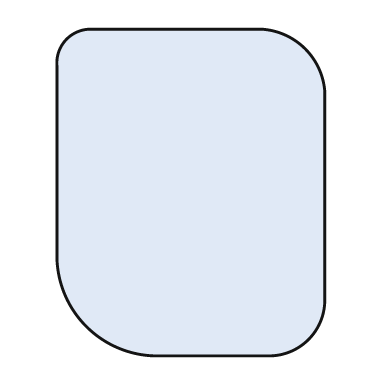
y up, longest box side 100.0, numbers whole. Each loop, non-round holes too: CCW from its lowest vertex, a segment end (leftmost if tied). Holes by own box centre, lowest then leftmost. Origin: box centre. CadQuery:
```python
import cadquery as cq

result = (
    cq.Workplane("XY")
    .moveTo(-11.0, -50.0)
    .lineTo(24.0, -50.0)
    .threePointArc((36.0, -45.0), (41.0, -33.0))
    .lineTo(41.0, 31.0)
    .threePointArc((35.0, 44.0), (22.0, 50.0))
    .lineTo(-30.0, 50.0)
    .threePointArc((-38.0, 47.0), (-41.0, 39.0))
    .lineTo(-41.0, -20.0)
    .threePointArc((-32.0, -41.0), (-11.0, -50.0))
    .close()
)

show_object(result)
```